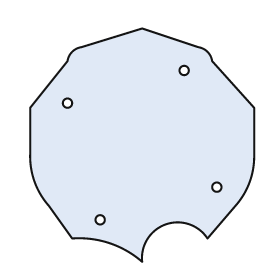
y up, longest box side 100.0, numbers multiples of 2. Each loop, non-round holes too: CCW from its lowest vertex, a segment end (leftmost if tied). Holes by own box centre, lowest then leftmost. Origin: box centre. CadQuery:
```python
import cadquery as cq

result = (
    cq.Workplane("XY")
    .moveTo(0.0, -50.0)
    .threePointArc((10.0, -34.0), (28.0, -40.0))
    .lineTo(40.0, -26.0)
    .threePointArc((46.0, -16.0), (48.0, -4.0))
    .lineTo(48.0, 16.0)
    .lineTo(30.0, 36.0)
    .threePointArc((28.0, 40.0), (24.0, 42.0))
    .lineTo(0.0, 50.0)
    .lineTo(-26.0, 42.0)
    .threePointArc((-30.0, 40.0), (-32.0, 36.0))
    .lineTo(-48.0, 16.0)
    .lineTo(-48.0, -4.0)
    .threePointArc((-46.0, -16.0), (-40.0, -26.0))
    .lineTo(-30.0, -40.0)
    .threePointArc((-14.0, -42.0), (0.0, -50.0))
    .close()
    .moveTo(-18.0, -32.0)
    .circle(2.0)
    .moveTo(32.0, -18.0)
    .circle(2.0)
    .moveTo(-32.0, 18.0)
    .circle(2.0)
    .moveTo(18.0, 32.0)
    .circle(2.0)
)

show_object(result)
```